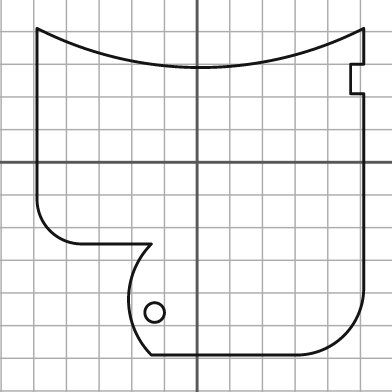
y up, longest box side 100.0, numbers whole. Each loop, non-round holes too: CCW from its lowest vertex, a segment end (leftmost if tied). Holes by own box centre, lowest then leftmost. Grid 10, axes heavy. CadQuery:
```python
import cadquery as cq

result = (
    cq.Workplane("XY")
    .moveTo(-14.0, -59.0)
    .lineTo(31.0, -59.0)
    .threePointArc((45.0, -53.0), (51.0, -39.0))
    .lineTo(51.0, 21.0)
    .lineTo(47.0, 21.0)
    .lineTo(47.0, 30.0)
    .lineTo(51.0, 30.0)
    .lineTo(51.0, 41.0)
    .threePointArc((1.0, 29.0), (-49.0, 41.0))
    .lineTo(-49.0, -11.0)
    .threePointArc((-45.0, -21.0), (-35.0, -25.0))
    .lineTo(-14.0, -25.0)
    .threePointArc((-21.0, -42.0), (-14.0, -59.0))
    .close()
    .moveTo(-13.0, -46.0)
    .circle(3.0)
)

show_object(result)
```